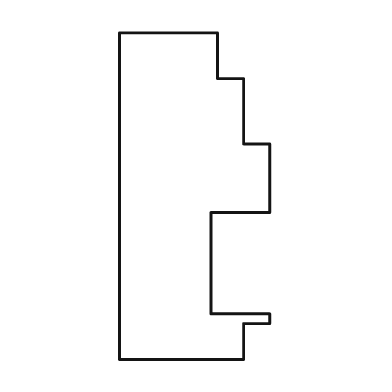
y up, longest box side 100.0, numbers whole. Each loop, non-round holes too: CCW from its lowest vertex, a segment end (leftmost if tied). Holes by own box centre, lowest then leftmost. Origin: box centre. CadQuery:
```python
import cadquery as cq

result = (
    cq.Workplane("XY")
    .moveTo(-23.0, -50.0)
    .lineTo(15.0, -50.0)
    .lineTo(15.0, -39.0)
    .lineTo(23.0, -39.0)
    .lineTo(23.0, -36.0)
    .lineTo(5.0, -36.0)
    .lineTo(5.0, -5.0)
    .lineTo(23.0, -5.0)
    .lineTo(23.0, 16.0)
    .lineTo(15.0, 16.0)
    .lineTo(15.0, 36.0)
    .lineTo(7.0, 36.0)
    .lineTo(7.0, 50.0)
    .lineTo(-23.0, 50.0)
    .close()
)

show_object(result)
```